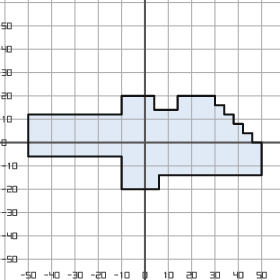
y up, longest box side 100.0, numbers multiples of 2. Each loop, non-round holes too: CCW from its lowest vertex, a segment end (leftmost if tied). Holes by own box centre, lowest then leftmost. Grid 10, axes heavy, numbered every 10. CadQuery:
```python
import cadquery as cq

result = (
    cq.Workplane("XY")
    .moveTo(-10.0, -20.0)
    .lineTo(6.0, -20.0)
    .lineTo(6.0, -14.0)
    .lineTo(50.0, -14.0)
    .lineTo(50.0, 0.0)
    .lineTo(46.0, 0.0)
    .lineTo(46.0, 4.0)
    .lineTo(42.0, 4.0)
    .lineTo(42.0, 8.0)
    .lineTo(38.0, 8.0)
    .lineTo(38.0, 12.0)
    .lineTo(34.0, 12.0)
    .lineTo(34.0, 16.0)
    .lineTo(30.0, 16.0)
    .lineTo(30.0, 20.0)
    .lineTo(14.0, 20.0)
    .lineTo(14.0, 14.0)
    .lineTo(4.0, 14.0)
    .lineTo(4.0, 20.0)
    .lineTo(-10.0, 20.0)
    .lineTo(-10.0, 12.0)
    .lineTo(-50.0, 12.0)
    .lineTo(-50.0, -6.0)
    .lineTo(-10.0, -6.0)
    .close()
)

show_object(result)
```